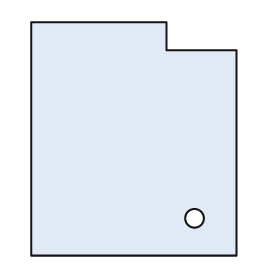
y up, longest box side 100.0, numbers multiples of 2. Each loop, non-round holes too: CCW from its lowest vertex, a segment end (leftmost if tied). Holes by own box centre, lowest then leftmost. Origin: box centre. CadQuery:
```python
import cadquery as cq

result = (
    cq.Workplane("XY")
    .moveTo(-44.0, -50.0)
    .lineTo(44.0, -50.0)
    .lineTo(44.0, 38.0)
    .lineTo(14.0, 38.0)
    .lineTo(14.0, 50.0)
    .lineTo(-44.0, 50.0)
    .close()
    .moveTo(26.0, -34.0)
    .circle(4.0)
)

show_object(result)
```